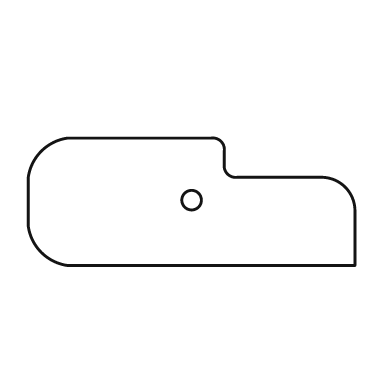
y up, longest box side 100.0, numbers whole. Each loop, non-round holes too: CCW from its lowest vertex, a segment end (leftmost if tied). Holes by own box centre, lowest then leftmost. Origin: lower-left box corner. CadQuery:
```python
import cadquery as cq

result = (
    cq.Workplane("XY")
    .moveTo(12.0, 0.0)
    .lineTo(100.0, 0.0)
    .lineTo(100.0, 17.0)
    .threePointArc((97.0, 24.0), (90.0, 27.0))
    .lineTo(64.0, 27.0)
    .threePointArc((61.0, 28.0), (60.0, 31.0))
    .lineTo(60.0, 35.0)
    .threePointArc((59.0, 38.0), (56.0, 39.0))
    .lineTo(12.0, 39.0)
    .threePointArc((4.0, 35.0), (0.0, 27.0))
    .lineTo(0.0, 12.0)
    .threePointArc((4.0, 4.0), (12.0, 0.0))
    .close()
    .moveTo(50.0, 20.0)
    .circle(3.0)
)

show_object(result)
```